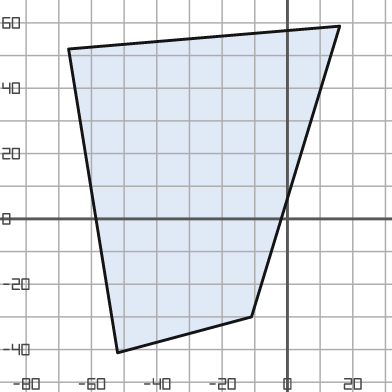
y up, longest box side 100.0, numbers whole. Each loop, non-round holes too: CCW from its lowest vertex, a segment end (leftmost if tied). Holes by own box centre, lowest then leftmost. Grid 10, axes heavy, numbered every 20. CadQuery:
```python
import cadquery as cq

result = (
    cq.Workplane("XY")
    .moveTo(-52.0, -41.0)
    .lineTo(-11.0, -30.0)
    .lineTo(16.0, 59.0)
    .lineTo(-67.0, 52.0)
    .close()
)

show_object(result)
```